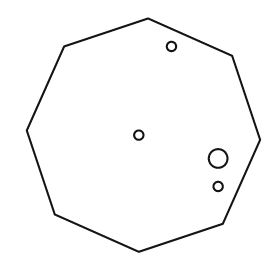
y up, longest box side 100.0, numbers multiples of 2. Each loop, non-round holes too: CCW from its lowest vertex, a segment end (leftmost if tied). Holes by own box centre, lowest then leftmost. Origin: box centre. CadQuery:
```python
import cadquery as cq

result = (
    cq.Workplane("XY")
    .moveTo(-2.0, -50.0)
    .lineTo(34.0, -38.0)
    .lineTo(50.0, -2.0)
    .lineTo(38.0, 34.0)
    .lineTo(2.0, 50.0)
    .lineTo(-34.0, 38.0)
    .lineTo(-50.0, 2.0)
    .lineTo(-38.0, -34.0)
    .close()
    .moveTo(32.0, -22.0)
    .circle(2.0)
    .moveTo(32.0, -10.0)
    .circle(4.0)
    .moveTo(-2.0, 0.0)
    .circle(2.0)
    .moveTo(12.0, 38.0)
    .circle(2.0)
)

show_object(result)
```